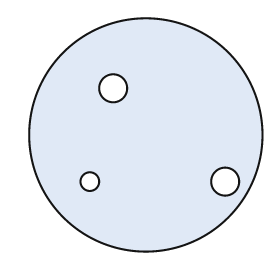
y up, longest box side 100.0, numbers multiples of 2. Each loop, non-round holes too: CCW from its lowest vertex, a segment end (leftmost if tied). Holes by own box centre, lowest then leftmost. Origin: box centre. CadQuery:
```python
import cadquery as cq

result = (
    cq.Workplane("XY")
    .moveTo(0.0, 0.0)
    .circle(50.0)
    .moveTo(-24.0, -20.0)
    .circle(4.0)
    .moveTo(34.0, -20.0)
    .circle(6.0)
    .moveTo(-14.0, 20.0)
    .circle(6.0)
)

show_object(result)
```